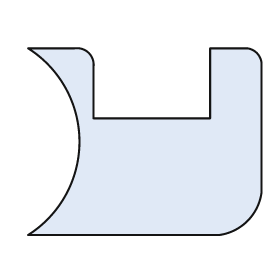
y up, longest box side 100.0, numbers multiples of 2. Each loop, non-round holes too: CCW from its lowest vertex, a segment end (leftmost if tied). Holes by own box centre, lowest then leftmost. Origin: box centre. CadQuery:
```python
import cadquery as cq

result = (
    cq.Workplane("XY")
    .moveTo(-50.0, -40.0)
    .lineTo(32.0, -40.0)
    .threePointArc((44.0, -34.0), (50.0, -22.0))
    .lineTo(50.0, 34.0)
    .threePointArc((48.0, 38.0), (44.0, 40.0))
    .lineTo(28.0, 40.0)
    .lineTo(28.0, 10.0)
    .lineTo(-22.0, 10.0)
    .lineTo(-22.0, 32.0)
    .threePointArc((-24.0, 38.0), (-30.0, 40.0))
    .lineTo(-50.0, 40.0)
    .threePointArc((-28.0, 0.0), (-50.0, -40.0))
    .close()
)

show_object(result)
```